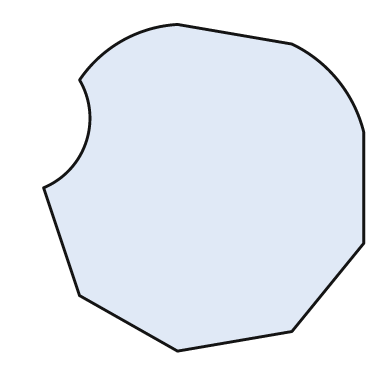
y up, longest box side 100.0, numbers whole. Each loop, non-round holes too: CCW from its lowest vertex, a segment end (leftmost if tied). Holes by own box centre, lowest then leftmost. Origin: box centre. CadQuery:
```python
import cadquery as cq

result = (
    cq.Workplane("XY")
    .moveTo(-8.0, -50.0)
    .lineTo(27.0, -44.0)
    .lineTo(49.0, -17.0)
    .lineTo(49.0, 17.0)
    .threePointArc((41.0, 33.0), (27.0, 44.0))
    .lineTo(-8.0, 50.0)
    .threePointArc((-25.0, 45.0), (-38.0, 33.0))
    .threePointArc((-36.0, 14.0), (-49.0, 0.0))
    .lineTo(-38.0, -33.0)
    .close()
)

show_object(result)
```